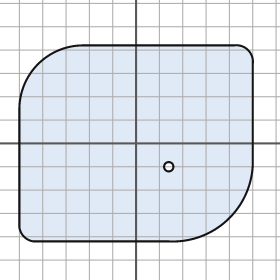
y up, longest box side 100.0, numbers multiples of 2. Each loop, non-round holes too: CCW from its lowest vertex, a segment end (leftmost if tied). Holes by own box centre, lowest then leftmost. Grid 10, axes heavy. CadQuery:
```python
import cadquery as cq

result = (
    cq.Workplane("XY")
    .moveTo(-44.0, -42.0)
    .lineTo(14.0, -42.0)
    .threePointArc((40.0, -32.0), (50.0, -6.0))
    .lineTo(50.0, 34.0)
    .threePointArc((48.0, 40.0), (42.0, 42.0))
    .lineTo(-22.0, 42.0)
    .threePointArc((-42.0, 34.0), (-50.0, 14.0))
    .lineTo(-50.0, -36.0)
    .threePointArc((-48.0, -40.0), (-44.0, -42.0))
    .close()
    .moveTo(14.0, -10.0)
    .circle(2.0)
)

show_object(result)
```